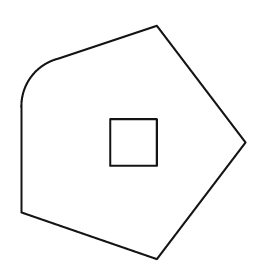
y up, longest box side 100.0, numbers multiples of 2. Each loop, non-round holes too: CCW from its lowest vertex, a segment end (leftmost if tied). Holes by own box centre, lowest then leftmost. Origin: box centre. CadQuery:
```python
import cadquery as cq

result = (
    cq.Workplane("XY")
    .moveTo(10.0, -50.0)
    .lineTo(48.0, 0.0)
    .lineTo(10.0, 50.0)
    .lineTo(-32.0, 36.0)
    .threePointArc((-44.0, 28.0), (-48.0, 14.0))
    .lineTo(-48.0, -30.0)
    .close()
    .moveTo(-10.0, -10.0)
    .lineTo(10.0, -10.0)
    .lineTo(10.0, 10.0)
    .lineTo(-10.0, 10.0)
    .close()
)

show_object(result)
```